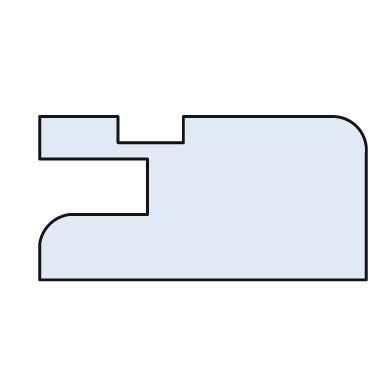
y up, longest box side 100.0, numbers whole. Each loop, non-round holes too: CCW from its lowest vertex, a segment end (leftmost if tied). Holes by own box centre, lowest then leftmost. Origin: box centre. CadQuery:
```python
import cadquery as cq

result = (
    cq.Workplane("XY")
    .moveTo(-50.0, -25.0)
    .lineTo(50.0, -25.0)
    .lineTo(50.0, 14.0)
    .threePointArc((47.0, 22.0), (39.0, 25.0))
    .lineTo(-6.0, 25.0)
    .lineTo(-6.0, 17.0)
    .lineTo(-26.0, 17.0)
    .lineTo(-26.0, 25.0)
    .lineTo(-50.0, 25.0)
    .lineTo(-50.0, 12.0)
    .lineTo(-17.0, 12.0)
    .lineTo(-17.0, -5.0)
    .lineTo(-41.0, -5.0)
    .threePointArc((-47.0, -8.0), (-50.0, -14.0))
    .close()
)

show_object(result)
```